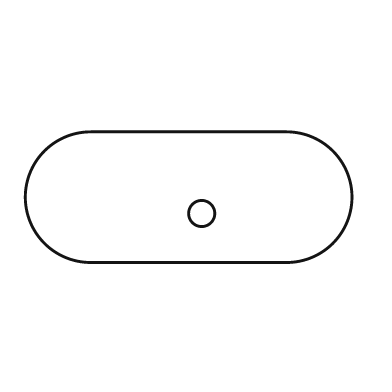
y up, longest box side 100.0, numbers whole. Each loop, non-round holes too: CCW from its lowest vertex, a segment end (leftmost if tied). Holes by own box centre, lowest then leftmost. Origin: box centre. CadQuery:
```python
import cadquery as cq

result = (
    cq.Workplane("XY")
    .moveTo(-30.0, -20.0)
    .lineTo(30.0, -20.0)
    .threePointArc((50.0, 0.0), (30.0, 20.0))
    .lineTo(-30.0, 20.0)
    .threePointArc((-50.0, 0.0), (-30.0, -20.0))
    .close()
    .moveTo(4.0, -5.0)
    .circle(4.0)
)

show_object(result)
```